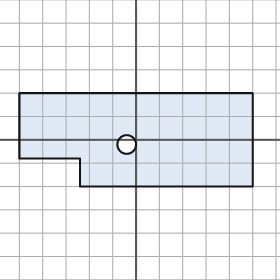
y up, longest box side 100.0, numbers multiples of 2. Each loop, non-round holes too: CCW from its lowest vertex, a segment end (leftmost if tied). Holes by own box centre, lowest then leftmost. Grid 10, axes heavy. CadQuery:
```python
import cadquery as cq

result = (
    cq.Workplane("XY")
    .moveTo(-24.0, -20.0)
    .lineTo(50.0, -20.0)
    .lineTo(50.0, 20.0)
    .lineTo(-50.0, 20.0)
    .lineTo(-50.0, -8.0)
    .lineTo(-24.0, -8.0)
    .close()
    .moveTo(-4.0, -2.0)
    .circle(4.0)
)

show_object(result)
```